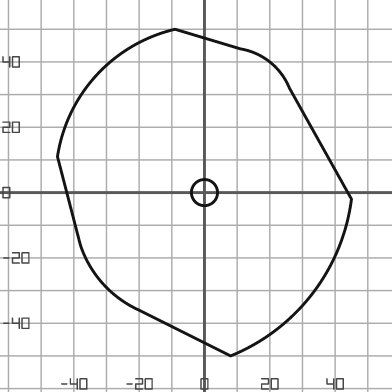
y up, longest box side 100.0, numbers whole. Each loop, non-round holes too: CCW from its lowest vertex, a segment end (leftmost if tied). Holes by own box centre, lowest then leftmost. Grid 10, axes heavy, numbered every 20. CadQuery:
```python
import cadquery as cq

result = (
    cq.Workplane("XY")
    .moveTo(8.0, -50.0)
    .threePointArc((33.0, -31.0), (45.0, -2.0))
    .lineTo(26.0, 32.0)
    .threePointArc((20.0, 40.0), (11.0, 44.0))
    .lineTo(-9.0, 50.0)
    .threePointArc((-33.0, 36.0), (-45.0, 11.0))
    .lineTo(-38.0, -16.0)
    .threePointArc((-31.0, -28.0), (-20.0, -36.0))
    .close()
    .moveTo(0.0, 0.0)
    .circle(4.0)
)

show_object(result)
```